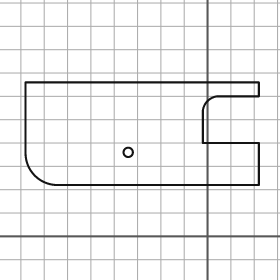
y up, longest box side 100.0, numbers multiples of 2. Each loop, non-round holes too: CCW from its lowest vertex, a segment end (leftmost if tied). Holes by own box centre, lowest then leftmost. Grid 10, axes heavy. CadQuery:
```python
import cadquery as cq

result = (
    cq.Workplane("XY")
    .moveTo(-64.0, 22.0)
    .lineTo(22.0, 22.0)
    .lineTo(22.0, 40.0)
    .lineTo(-2.0, 40.0)
    .lineTo(-2.0, 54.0)
    .threePointArc((0.0, 58.0), (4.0, 60.0))
    .lineTo(22.0, 60.0)
    .lineTo(22.0, 66.0)
    .lineTo(-78.0, 66.0)
    .lineTo(-78.0, 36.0)
    .threePointArc((-74.0, 26.0), (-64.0, 22.0))
    .close()
    .moveTo(-34.0, 36.0)
    .circle(2.0)
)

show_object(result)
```